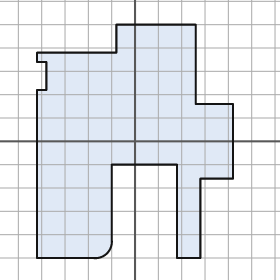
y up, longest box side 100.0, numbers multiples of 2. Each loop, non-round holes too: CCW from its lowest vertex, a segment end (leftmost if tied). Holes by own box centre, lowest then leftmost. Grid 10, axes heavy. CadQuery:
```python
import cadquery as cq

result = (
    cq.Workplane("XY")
    .moveTo(-42.0, -50.0)
    .lineTo(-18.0, -50.0)
    .threePointArc((-12.0, -48.0), (-10.0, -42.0))
    .lineTo(-10.0, -10.0)
    .lineTo(18.0, -10.0)
    .lineTo(18.0, -50.0)
    .lineTo(28.0, -50.0)
    .lineTo(28.0, -16.0)
    .lineTo(42.0, -16.0)
    .lineTo(42.0, 16.0)
    .lineTo(26.0, 16.0)
    .lineTo(26.0, 50.0)
    .lineTo(-8.0, 50.0)
    .lineTo(-8.0, 38.0)
    .lineTo(-42.0, 38.0)
    .lineTo(-42.0, 34.0)
    .lineTo(-38.0, 34.0)
    .lineTo(-38.0, 22.0)
    .lineTo(-42.0, 22.0)
    .close()
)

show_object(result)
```